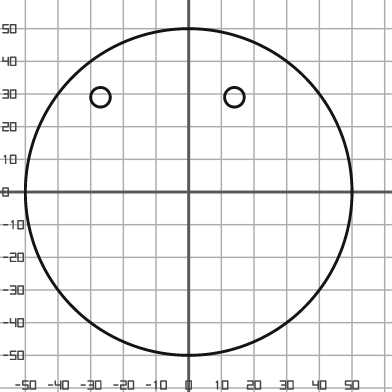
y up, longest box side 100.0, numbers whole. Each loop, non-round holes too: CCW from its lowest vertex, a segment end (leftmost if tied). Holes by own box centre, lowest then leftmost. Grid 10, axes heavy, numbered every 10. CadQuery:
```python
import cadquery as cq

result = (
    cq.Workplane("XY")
    .moveTo(0.0, 0.0)
    .circle(50.0)
    .moveTo(-27.0, 29.0)
    .circle(3.0)
    .moveTo(14.0, 29.0)
    .circle(3.0)
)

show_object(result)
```